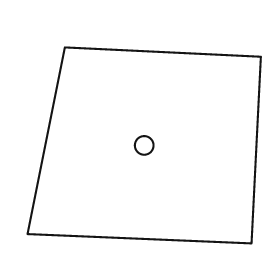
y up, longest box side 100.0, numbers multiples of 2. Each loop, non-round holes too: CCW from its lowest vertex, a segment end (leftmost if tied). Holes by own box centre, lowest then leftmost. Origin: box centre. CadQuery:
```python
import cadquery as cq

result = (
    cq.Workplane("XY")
    .moveTo(46.0, -42.0)
    .lineTo(50.0, 38.0)
    .lineTo(-34.0, 42.0)
    .lineTo(-50.0, -38.0)
    .close()
    .moveTo(0.0, 0.0)
    .circle(4.0)
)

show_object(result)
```